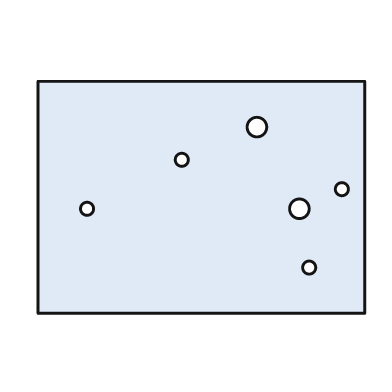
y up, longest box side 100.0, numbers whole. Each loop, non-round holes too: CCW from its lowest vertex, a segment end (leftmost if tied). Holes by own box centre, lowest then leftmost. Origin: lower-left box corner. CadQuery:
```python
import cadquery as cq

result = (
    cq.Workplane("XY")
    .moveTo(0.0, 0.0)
    .lineTo(100.0, 0.0)
    .lineTo(100.0, 71.0)
    .lineTo(0.0, 71.0)
    .close()
    .moveTo(83.0, 14.0)
    .circle(2.0)
    .moveTo(15.0, 32.0)
    .circle(2.0)
    .moveTo(80.0, 32.0)
    .circle(3.0)
    .moveTo(93.0, 38.0)
    .circle(2.0)
    .moveTo(44.0, 47.0)
    .circle(2.0)
    .moveTo(67.0, 57.0)
    .circle(3.0)
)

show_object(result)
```